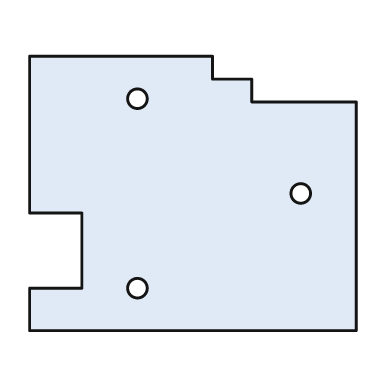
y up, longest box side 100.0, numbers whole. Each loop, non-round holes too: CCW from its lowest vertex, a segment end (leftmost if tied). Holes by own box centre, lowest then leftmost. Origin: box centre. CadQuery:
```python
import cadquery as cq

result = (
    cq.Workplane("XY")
    .moveTo(-50.0, -42.0)
    .lineTo(50.0, -42.0)
    .lineTo(50.0, 28.0)
    .lineTo(18.0, 28.0)
    .lineTo(18.0, 35.0)
    .lineTo(6.0, 35.0)
    .lineTo(6.0, 42.0)
    .lineTo(-50.0, 42.0)
    .lineTo(-50.0, -6.0)
    .lineTo(-34.0, -6.0)
    .lineTo(-34.0, -29.0)
    .lineTo(-50.0, -29.0)
    .close()
    .moveTo(-17.0, -29.0)
    .circle(3.0)
    .moveTo(33.0, 0.0)
    .circle(3.0)
    .moveTo(-17.0, 29.0)
    .circle(3.0)
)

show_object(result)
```